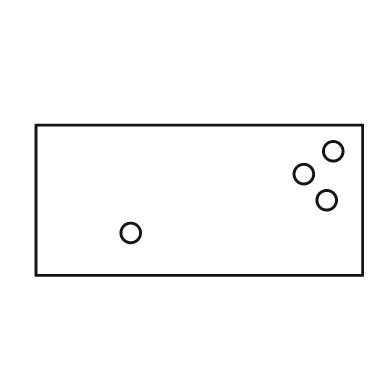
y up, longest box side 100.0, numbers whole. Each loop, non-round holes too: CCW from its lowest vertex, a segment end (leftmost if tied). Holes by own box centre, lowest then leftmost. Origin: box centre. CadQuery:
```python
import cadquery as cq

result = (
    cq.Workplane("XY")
    .moveTo(-50.0, -23.0)
    .lineTo(50.0, -23.0)
    .lineTo(50.0, 23.0)
    .lineTo(-50.0, 23.0)
    .close()
    .moveTo(-21.0, -10.0)
    .circle(3.0)
    .moveTo(39.0, 0.0)
    .circle(3.0)
    .moveTo(32.0, 8.0)
    .circle(3.0)
    .moveTo(41.0, 15.0)
    .circle(3.0)
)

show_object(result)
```